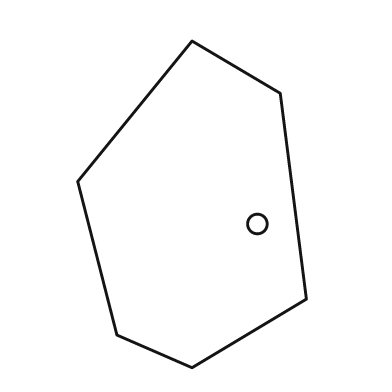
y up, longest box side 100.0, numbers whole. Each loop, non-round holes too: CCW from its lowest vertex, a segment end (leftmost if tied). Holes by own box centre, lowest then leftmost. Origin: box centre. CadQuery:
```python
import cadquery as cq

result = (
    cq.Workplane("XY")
    .moveTo(0.0, -50.0)
    .lineTo(35.0, -29.0)
    .lineTo(27.0, 34.0)
    .lineTo(0.0, 50.0)
    .lineTo(-35.0, 7.0)
    .lineTo(-23.0, -40.0)
    .close()
    .moveTo(20.0, -6.0)
    .circle(3.0)
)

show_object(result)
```